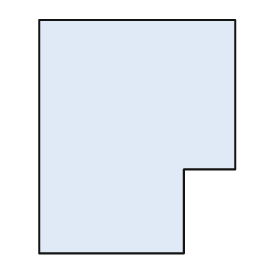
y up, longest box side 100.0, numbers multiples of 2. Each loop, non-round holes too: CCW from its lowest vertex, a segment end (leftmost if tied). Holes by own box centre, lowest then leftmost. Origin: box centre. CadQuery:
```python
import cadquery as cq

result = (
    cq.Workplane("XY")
    .moveTo(-42.0, -50.0)
    .lineTo(20.0, -50.0)
    .lineTo(20.0, -14.0)
    .lineTo(42.0, -14.0)
    .lineTo(42.0, 50.0)
    .lineTo(-42.0, 50.0)
    .close()
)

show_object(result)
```